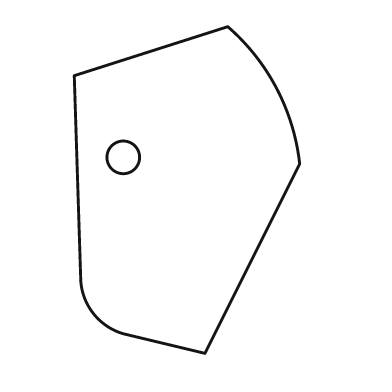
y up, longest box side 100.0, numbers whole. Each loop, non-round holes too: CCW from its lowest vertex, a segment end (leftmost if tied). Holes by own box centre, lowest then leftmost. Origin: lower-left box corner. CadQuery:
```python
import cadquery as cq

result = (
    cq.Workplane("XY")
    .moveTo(40.0, 0.0)
    .lineTo(69.0, 58.0)
    .threePointArc((62.0, 81.0), (47.0, 100.0))
    .lineTo(0.0, 85.0)
    .lineTo(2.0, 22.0)
    .threePointArc((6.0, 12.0), (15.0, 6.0))
    .close()
    .moveTo(15.0, 60.0)
    .circle(5.0)
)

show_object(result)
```